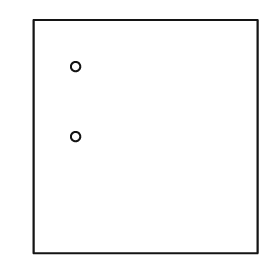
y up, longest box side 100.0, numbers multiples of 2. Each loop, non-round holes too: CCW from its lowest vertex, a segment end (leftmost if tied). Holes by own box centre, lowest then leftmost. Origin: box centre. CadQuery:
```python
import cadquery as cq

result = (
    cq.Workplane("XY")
    .moveTo(-48.0, -50.0)
    .lineTo(48.0, -50.0)
    .lineTo(48.0, 50.0)
    .lineTo(-48.0, 50.0)
    .close()
    .moveTo(-30.0, 0.0)
    .circle(2.0)
    .moveTo(-30.0, 30.0)
    .circle(2.0)
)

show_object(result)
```